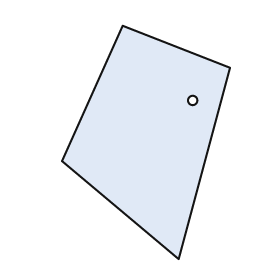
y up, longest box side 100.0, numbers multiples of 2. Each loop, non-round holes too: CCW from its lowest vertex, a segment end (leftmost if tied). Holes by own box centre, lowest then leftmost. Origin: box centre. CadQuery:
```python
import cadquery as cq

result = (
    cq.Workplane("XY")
    .moveTo(14.0, -50.0)
    .lineTo(36.0, 32.0)
    .lineTo(-10.0, 50.0)
    .lineTo(-36.0, -8.0)
    .close()
    .moveTo(20.0, 18.0)
    .circle(2.0)
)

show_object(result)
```